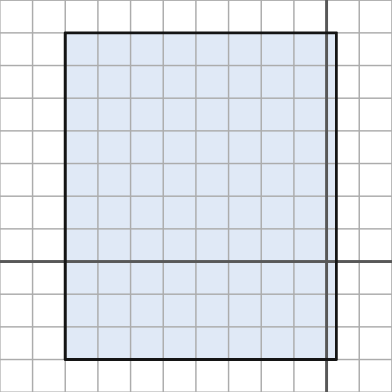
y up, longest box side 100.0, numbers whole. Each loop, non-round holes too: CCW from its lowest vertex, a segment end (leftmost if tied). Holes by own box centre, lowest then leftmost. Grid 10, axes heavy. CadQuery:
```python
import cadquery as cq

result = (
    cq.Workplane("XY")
    .moveTo(-80.0, -30.0)
    .lineTo(3.0, -30.0)
    .lineTo(3.0, 70.0)
    .lineTo(-80.0, 70.0)
    .close()
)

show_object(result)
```